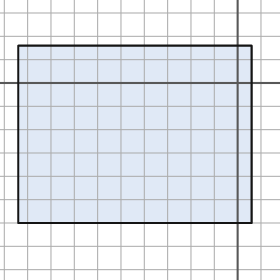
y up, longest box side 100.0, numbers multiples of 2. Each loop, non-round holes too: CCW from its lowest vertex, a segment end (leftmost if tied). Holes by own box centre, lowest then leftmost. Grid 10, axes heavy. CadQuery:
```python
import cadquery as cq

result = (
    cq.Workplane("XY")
    .moveTo(-94.0, -60.0)
    .lineTo(6.0, -60.0)
    .lineTo(6.0, 16.0)
    .lineTo(-94.0, 16.0)
    .close()
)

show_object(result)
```